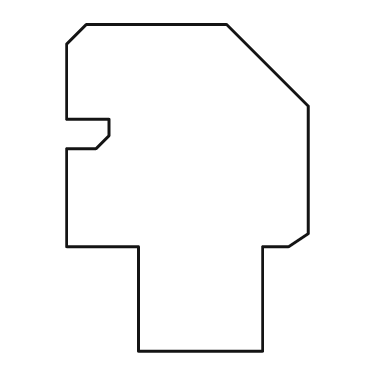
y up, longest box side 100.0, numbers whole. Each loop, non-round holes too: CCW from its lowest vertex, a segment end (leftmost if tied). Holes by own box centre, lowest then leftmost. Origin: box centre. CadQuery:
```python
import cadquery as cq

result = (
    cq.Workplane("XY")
    .moveTo(-15.0, -50.0)
    .lineTo(23.0, -50.0)
    .lineTo(23.0, -18.0)
    .lineTo(31.0, -18.0)
    .lineTo(37.0, -14.0)
    .lineTo(37.0, 25.0)
    .lineTo(12.0, 50.0)
    .lineTo(-31.0, 50.0)
    .lineTo(-37.0, 44.0)
    .lineTo(-37.0, 21.0)
    .lineTo(-24.0, 21.0)
    .lineTo(-24.0, 16.0)
    .lineTo(-28.0, 12.0)
    .lineTo(-37.0, 12.0)
    .lineTo(-37.0, -18.0)
    .lineTo(-15.0, -18.0)
    .close()
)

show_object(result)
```